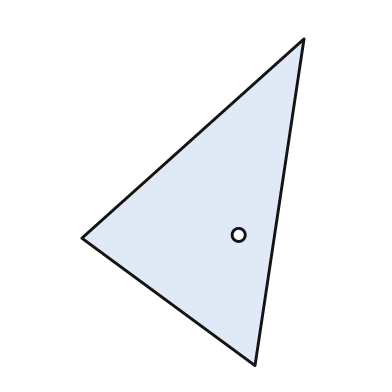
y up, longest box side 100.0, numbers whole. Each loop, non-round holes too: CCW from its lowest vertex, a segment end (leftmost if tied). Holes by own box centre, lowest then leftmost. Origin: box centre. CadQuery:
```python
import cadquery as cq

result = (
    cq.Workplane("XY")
    .moveTo(19.0, -50.0)
    .lineTo(34.0, 50.0)
    .lineTo(-34.0, -11.0)
    .close()
    .moveTo(14.0, -10.0)
    .circle(2.0)
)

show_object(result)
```